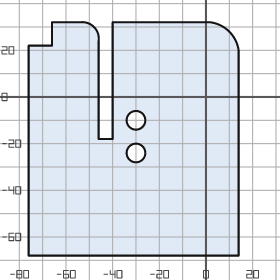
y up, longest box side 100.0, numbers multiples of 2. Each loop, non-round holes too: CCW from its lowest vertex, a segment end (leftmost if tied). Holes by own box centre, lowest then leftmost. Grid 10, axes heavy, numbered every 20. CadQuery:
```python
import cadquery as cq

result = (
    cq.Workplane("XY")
    .moveTo(-76.0, -68.0)
    .lineTo(14.0, -68.0)
    .lineTo(14.0, 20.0)
    .threePointArc((10.0, 28.0), (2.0, 32.0))
    .lineTo(-40.0, 32.0)
    .lineTo(-40.0, -18.0)
    .lineTo(-46.0, -18.0)
    .lineTo(-46.0, 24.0)
    .threePointArc((-48.0, 30.0), (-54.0, 32.0))
    .lineTo(-66.0, 32.0)
    .lineTo(-66.0, 22.0)
    .lineTo(-76.0, 22.0)
    .close()
    .moveTo(-30.0, -24.0)
    .circle(4.0)
    .moveTo(-30.0, -10.0)
    .circle(4.0)
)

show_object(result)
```